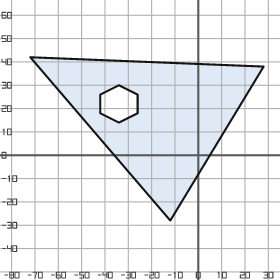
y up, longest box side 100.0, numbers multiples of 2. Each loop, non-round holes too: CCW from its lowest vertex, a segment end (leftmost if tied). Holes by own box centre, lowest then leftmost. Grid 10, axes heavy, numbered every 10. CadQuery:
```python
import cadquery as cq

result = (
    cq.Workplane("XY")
    .moveTo(-12.0, -28.0)
    .lineTo(28.0, 38.0)
    .lineTo(-72.0, 42.0)
    .close()
    .moveTo(-34.0, 14.0)
    .lineTo(-26.0, 18.0)
    .lineTo(-26.0, 26.0)
    .lineTo(-34.0, 30.0)
    .lineTo(-42.0, 26.0)
    .lineTo(-42.0, 18.0)
    .close()
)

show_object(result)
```